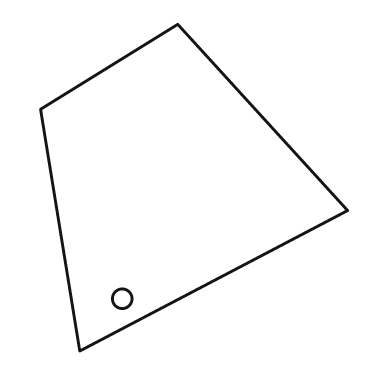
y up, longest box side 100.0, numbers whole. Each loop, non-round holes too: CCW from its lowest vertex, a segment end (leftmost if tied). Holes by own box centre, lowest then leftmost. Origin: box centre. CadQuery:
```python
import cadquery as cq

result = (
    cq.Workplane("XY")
    .moveTo(-35.0, -50.0)
    .lineTo(47.0, -7.0)
    .lineTo(-5.0, 50.0)
    .lineTo(-47.0, 24.0)
    .close()
    .moveTo(-22.0, -34.0)
    .circle(3.0)
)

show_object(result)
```